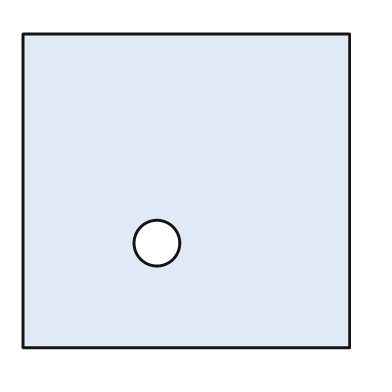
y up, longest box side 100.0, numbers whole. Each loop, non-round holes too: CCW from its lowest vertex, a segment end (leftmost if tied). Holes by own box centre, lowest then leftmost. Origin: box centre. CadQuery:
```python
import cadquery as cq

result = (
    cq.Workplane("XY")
    .moveTo(-50.0, -48.0)
    .lineTo(50.0, -48.0)
    .lineTo(50.0, 48.0)
    .lineTo(-50.0, 48.0)
    .close()
    .moveTo(-9.0, -16.0)
    .circle(7.0)
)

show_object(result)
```